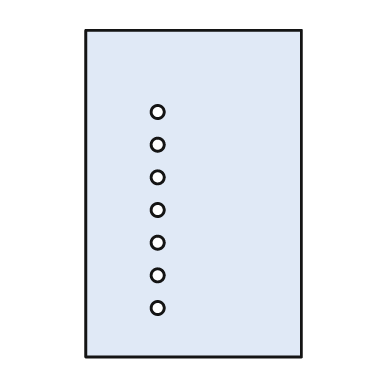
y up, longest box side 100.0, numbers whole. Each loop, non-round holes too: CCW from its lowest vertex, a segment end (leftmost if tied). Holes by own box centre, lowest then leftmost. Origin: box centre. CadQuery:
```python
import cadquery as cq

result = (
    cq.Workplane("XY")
    .moveTo(-33.0, -50.0)
    .lineTo(33.0, -50.0)
    .lineTo(33.0, 50.0)
    .lineTo(-33.0, 50.0)
    .close()
    .moveTo(-11.0, -35.0)
    .circle(2.0)
    .moveTo(-11.0, -25.0)
    .circle(2.0)
    .moveTo(-11.0, -15.0)
    .circle(2.0)
    .moveTo(-11.0, -5.0)
    .circle(2.0)
    .moveTo(-11.0, 5.0)
    .circle(2.0)
    .moveTo(-11.0, 15.0)
    .circle(2.0)
    .moveTo(-11.0, 25.0)
    .circle(2.0)
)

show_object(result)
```